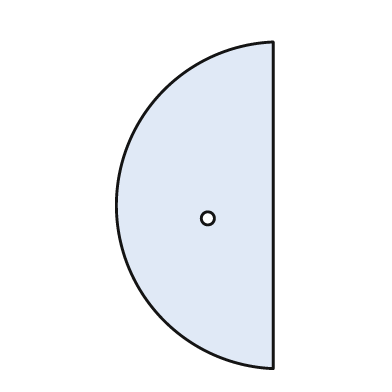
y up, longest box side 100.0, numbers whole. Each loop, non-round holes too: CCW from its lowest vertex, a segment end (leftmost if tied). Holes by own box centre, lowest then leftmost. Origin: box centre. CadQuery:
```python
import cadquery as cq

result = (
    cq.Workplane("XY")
    .moveTo(24.0, -50.0)
    .lineTo(24.0, 50.0)
    .threePointArc((-24.0, 0.0), (24.0, -50.0))
    .close()
    .moveTo(4.0, -4.0)
    .circle(2.0)
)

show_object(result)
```